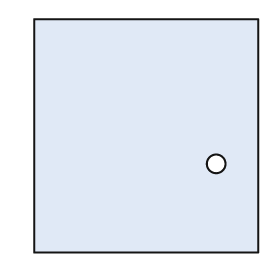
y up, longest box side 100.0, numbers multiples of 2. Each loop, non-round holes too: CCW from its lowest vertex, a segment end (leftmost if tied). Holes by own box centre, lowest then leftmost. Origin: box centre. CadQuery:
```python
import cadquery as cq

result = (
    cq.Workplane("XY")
    .moveTo(-48.0, -50.0)
    .lineTo(48.0, -50.0)
    .lineTo(48.0, 50.0)
    .lineTo(-48.0, 50.0)
    .close()
    .moveTo(30.0, -12.0)
    .circle(4.0)
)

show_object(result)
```